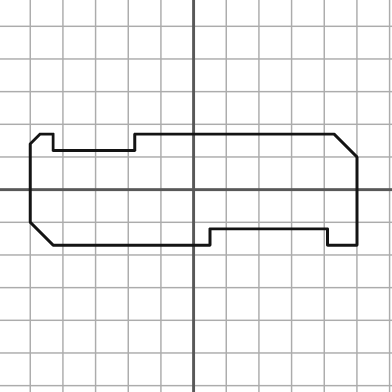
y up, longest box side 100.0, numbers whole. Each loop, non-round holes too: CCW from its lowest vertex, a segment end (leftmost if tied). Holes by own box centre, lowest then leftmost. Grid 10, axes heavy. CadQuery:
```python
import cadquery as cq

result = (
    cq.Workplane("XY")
    .moveTo(-43.0, -17.0)
    .lineTo(5.0, -17.0)
    .lineTo(5.0, -12.0)
    .lineTo(41.0, -12.0)
    .lineTo(41.0, -17.0)
    .lineTo(50.0, -17.0)
    .lineTo(50.0, 10.0)
    .lineTo(43.0, 17.0)
    .lineTo(-18.0, 17.0)
    .lineTo(-18.0, 12.0)
    .lineTo(-43.0, 12.0)
    .lineTo(-43.0, 17.0)
    .lineTo(-47.0, 17.0)
    .lineTo(-50.0, 14.0)
    .lineTo(-50.0, -10.0)
    .close()
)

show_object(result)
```